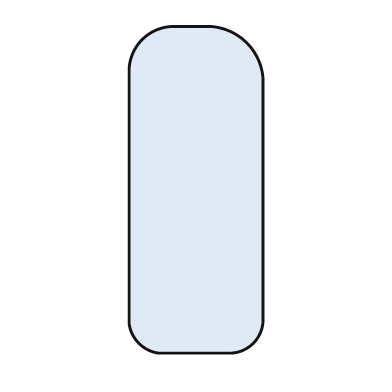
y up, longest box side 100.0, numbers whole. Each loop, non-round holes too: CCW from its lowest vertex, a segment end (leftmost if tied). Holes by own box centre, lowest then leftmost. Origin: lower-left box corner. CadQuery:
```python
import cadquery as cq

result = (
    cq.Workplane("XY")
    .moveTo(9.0, 0.0)
    .lineTo(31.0, 0.0)
    .threePointArc((38.0, 3.0), (41.0, 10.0))
    .lineTo(41.0, 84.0)
    .threePointArc((36.0, 95.0), (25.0, 100.0))
    .lineTo(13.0, 100.0)
    .threePointArc((4.0, 96.0), (0.0, 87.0))
    .lineTo(0.0, 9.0)
    .threePointArc((3.0, 3.0), (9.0, 0.0))
    .close()
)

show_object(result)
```